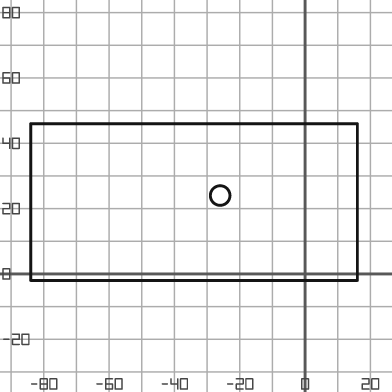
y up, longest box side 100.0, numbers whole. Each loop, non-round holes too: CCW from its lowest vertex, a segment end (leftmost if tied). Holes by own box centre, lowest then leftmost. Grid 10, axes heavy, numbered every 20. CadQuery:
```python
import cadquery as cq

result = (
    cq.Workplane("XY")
    .moveTo(-84.0, -2.0)
    .lineTo(16.0, -2.0)
    .lineTo(16.0, 46.0)
    .lineTo(-84.0, 46.0)
    .close()
    .moveTo(-26.0, 24.0)
    .circle(3.0)
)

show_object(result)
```